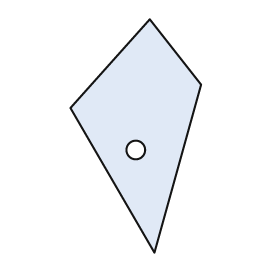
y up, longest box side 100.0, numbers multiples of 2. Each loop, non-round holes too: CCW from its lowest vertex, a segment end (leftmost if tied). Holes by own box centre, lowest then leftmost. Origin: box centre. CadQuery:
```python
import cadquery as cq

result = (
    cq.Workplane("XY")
    .moveTo(8.0, -50.0)
    .lineTo(28.0, 22.0)
    .lineTo(6.0, 50.0)
    .lineTo(-28.0, 12.0)
    .close()
    .moveTo(0.0, -6.0)
    .circle(4.0)
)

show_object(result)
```